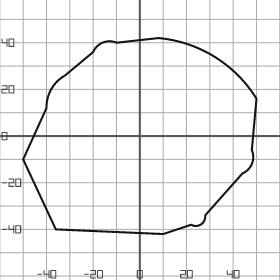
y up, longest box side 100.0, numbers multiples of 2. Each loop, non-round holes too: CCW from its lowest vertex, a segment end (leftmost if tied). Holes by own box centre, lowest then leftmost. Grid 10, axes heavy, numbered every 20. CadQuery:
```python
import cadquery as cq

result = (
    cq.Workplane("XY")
    .moveTo(10.0, -42.0)
    .lineTo(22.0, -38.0)
    .threePointArc((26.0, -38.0), (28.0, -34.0))
    .lineTo(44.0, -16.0)
    .threePointArc((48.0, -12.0), (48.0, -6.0))
    .lineTo(50.0, 16.0)
    .threePointArc((32.0, 34.0), (8.0, 42.0))
    .lineTo(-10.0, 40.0)
    .threePointArc((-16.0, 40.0), (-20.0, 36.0))
    .lineTo(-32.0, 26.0)
    .threePointArc((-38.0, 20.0), (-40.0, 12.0))
    .lineTo(-50.0, -10.0)
    .lineTo(-36.0, -40.0)
    .close()
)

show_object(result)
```